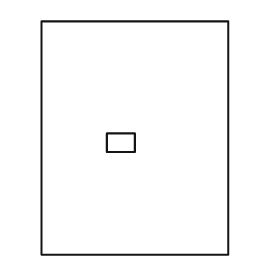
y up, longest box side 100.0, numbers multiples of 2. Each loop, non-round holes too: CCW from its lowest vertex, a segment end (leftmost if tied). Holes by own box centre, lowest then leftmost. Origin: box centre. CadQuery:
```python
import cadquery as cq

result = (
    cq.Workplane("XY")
    .moveTo(-40.0, -50.0)
    .lineTo(40.0, -50.0)
    .lineTo(40.0, 50.0)
    .lineTo(-40.0, 50.0)
    .close()
    .moveTo(-12.0, -6.0)
    .lineTo(0.0, -6.0)
    .lineTo(0.0, 2.0)
    .lineTo(-12.0, 2.0)
    .close()
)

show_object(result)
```